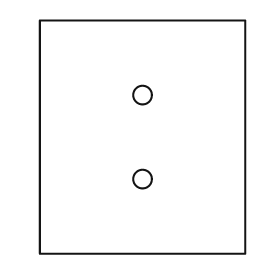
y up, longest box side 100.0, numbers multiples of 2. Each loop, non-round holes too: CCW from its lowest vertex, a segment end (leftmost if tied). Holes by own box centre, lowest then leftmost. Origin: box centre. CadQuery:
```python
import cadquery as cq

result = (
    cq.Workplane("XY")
    .moveTo(-44.0, -50.0)
    .lineTo(44.0, -50.0)
    .lineTo(44.0, 50.0)
    .lineTo(-44.0, 50.0)
    .close()
    .moveTo(0.0, -18.0)
    .circle(4.0)
    .moveTo(0.0, 18.0)
    .circle(4.0)
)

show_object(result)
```